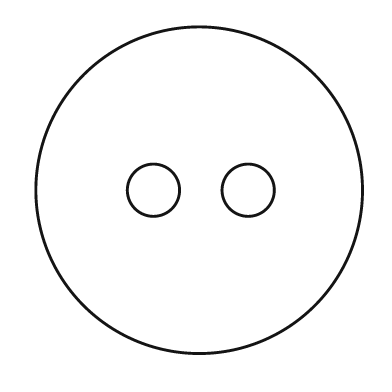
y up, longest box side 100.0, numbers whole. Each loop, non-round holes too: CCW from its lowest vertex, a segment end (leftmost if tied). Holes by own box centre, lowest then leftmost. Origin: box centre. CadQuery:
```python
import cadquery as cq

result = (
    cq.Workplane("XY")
    .moveTo(0.0, 0.0)
    .circle(50.0)
    .moveTo(-14.0, 0.0)
    .circle(8.0)
    .moveTo(15.0, 0.0)
    .circle(8.0)
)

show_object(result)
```